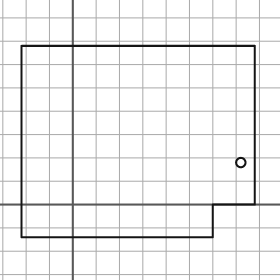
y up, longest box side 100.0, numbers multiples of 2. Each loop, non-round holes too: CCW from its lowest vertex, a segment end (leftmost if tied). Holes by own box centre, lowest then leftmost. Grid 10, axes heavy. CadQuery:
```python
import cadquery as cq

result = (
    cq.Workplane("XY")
    .moveTo(-22.0, -14.0)
    .lineTo(60.0, -14.0)
    .lineTo(60.0, 0.0)
    .lineTo(78.0, 0.0)
    .lineTo(78.0, 68.0)
    .lineTo(-22.0, 68.0)
    .close()
    .moveTo(72.0, 18.0)
    .circle(2.0)
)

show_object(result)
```